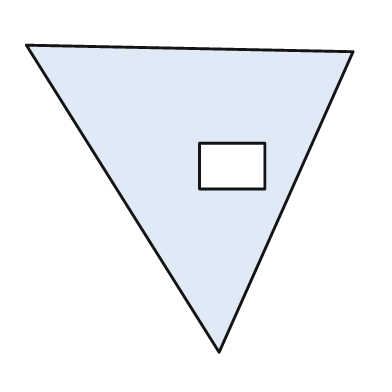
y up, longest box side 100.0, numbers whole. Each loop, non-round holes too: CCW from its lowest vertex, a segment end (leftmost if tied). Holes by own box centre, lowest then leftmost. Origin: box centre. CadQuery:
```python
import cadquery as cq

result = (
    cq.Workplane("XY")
    .moveTo(9.0, -47.0)
    .lineTo(50.0, 45.0)
    .lineTo(-50.0, 47.0)
    .close()
    .moveTo(3.0, 3.0)
    .lineTo(23.0, 3.0)
    .lineTo(23.0, 17.0)
    .lineTo(3.0, 17.0)
    .close()
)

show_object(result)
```